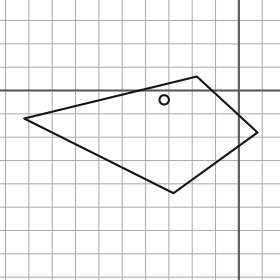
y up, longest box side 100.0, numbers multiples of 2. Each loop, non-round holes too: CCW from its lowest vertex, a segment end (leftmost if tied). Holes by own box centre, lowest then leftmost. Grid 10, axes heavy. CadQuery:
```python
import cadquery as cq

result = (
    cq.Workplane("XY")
    .moveTo(-28.0, -44.0)
    .lineTo(8.0, -18.0)
    .lineTo(-18.0, 6.0)
    .lineTo(-92.0, -12.0)
    .close()
    .moveTo(-32.0, -4.0)
    .circle(2.0)
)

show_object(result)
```